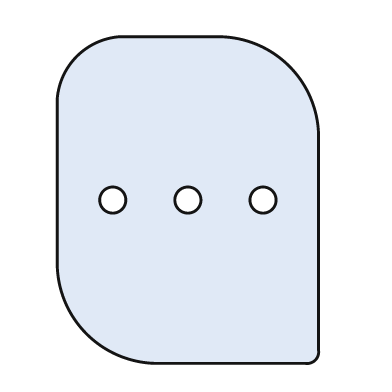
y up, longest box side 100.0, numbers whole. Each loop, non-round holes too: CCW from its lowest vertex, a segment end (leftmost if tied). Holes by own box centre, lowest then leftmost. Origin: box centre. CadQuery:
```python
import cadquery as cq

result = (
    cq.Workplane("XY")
    .moveTo(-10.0, -50.0)
    .lineTo(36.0, -50.0)
    .threePointArc((39.0, -49.0), (40.0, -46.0))
    .lineTo(40.0, 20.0)
    .threePointArc((31.0, 41.0), (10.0, 50.0))
    .lineTo(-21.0, 50.0)
    .threePointArc((-34.0, 44.0), (-40.0, 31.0))
    .lineTo(-40.0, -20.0)
    .threePointArc((-31.0, -41.0), (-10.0, -50.0))
    .close()
    .moveTo(-23.0, 0.0)
    .circle(4.0)
    .moveTo(0.0, 0.0)
    .circle(4.0)
    .moveTo(23.0, 0.0)
    .circle(4.0)
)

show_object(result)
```